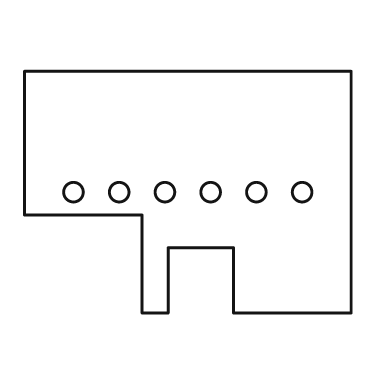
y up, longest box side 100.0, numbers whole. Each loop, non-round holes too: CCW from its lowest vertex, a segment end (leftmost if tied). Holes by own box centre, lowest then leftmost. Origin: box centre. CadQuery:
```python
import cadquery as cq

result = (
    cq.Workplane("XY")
    .moveTo(-14.0, -37.0)
    .lineTo(-6.0, -37.0)
    .lineTo(-6.0, -17.0)
    .lineTo(14.0, -17.0)
    .lineTo(14.0, -37.0)
    .lineTo(50.0, -37.0)
    .lineTo(50.0, 37.0)
    .lineTo(-50.0, 37.0)
    .lineTo(-50.0, -7.0)
    .lineTo(-14.0, -7.0)
    .close()
    .moveTo(-35.0, 0.0)
    .circle(3.0)
    .moveTo(-21.0, 0.0)
    .circle(3.0)
    .moveTo(-7.0, 0.0)
    .circle(3.0)
    .moveTo(7.0, 0.0)
    .circle(3.0)
    .moveTo(21.0, 0.0)
    .circle(3.0)
    .moveTo(35.0, 0.0)
    .circle(3.0)
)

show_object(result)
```